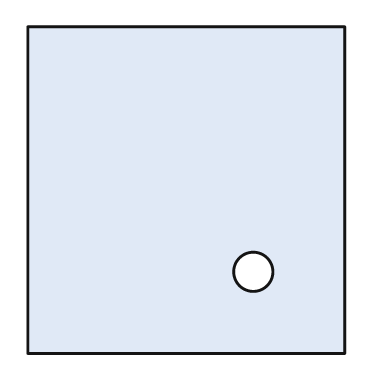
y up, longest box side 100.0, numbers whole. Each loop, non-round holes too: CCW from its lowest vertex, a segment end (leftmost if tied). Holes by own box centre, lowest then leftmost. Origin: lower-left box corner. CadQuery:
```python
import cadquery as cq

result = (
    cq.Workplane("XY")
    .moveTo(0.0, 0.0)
    .lineTo(97.0, 0.0)
    .lineTo(97.0, 100.0)
    .lineTo(0.0, 100.0)
    .close()
    .moveTo(69.0, 25.0)
    .circle(6.0)
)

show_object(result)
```